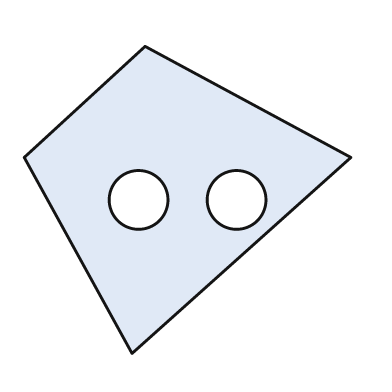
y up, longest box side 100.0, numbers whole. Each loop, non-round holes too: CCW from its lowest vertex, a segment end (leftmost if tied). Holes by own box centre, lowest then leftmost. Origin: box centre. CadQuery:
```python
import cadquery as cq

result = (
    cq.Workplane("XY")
    .moveTo(-17.0, -47.0)
    .lineTo(50.0, 13.0)
    .lineTo(-13.0, 47.0)
    .lineTo(-50.0, 13.0)
    .close()
    .moveTo(-15.0, 0.0)
    .circle(9.0)
    .moveTo(15.0, 0.0)
    .circle(9.0)
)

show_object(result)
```